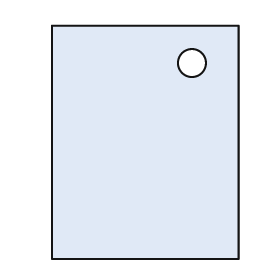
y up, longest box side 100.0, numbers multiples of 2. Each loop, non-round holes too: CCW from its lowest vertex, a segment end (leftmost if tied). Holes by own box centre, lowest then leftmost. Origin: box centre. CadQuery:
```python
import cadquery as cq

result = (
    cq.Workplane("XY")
    .moveTo(-40.0, -50.0)
    .lineTo(40.0, -50.0)
    .lineTo(40.0, 50.0)
    .lineTo(-40.0, 50.0)
    .close()
    .moveTo(20.0, 34.0)
    .circle(6.0)
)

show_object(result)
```